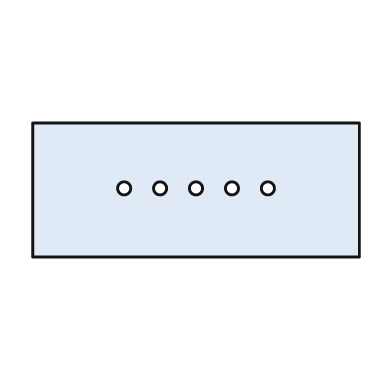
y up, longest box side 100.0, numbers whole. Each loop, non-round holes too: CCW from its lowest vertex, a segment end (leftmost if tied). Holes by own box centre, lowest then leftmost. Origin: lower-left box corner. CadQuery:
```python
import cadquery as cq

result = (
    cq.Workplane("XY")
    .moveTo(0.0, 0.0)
    .lineTo(100.0, 0.0)
    .lineTo(100.0, 41.0)
    .lineTo(0.0, 41.0)
    .close()
    .moveTo(28.0, 21.0)
    .circle(2.0)
    .moveTo(39.0, 21.0)
    .circle(2.0)
    .moveTo(50.0, 21.0)
    .circle(2.0)
    .moveTo(61.0, 21.0)
    .circle(2.0)
    .moveTo(72.0, 21.0)
    .circle(2.0)
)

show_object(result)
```